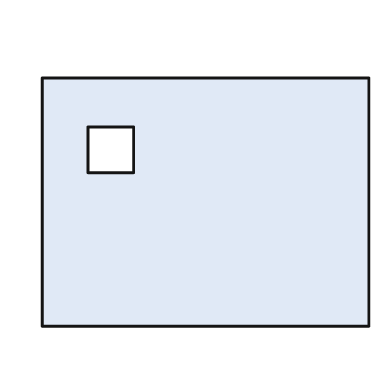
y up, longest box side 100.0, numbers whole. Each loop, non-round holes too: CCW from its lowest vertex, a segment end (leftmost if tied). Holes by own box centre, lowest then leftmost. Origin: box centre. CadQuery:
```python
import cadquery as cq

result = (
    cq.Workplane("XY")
    .moveTo(-50.0, -38.0)
    .lineTo(50.0, -38.0)
    .lineTo(50.0, 38.0)
    .lineTo(-50.0, 38.0)
    .close()
    .moveTo(-36.0, 9.0)
    .lineTo(-22.0, 9.0)
    .lineTo(-22.0, 23.0)
    .lineTo(-36.0, 23.0)
    .close()
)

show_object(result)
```